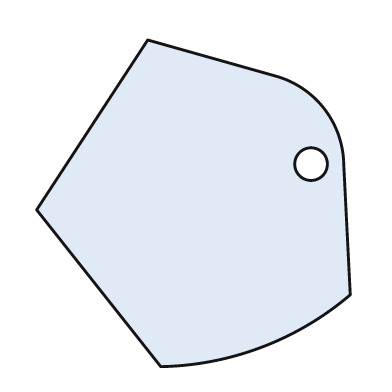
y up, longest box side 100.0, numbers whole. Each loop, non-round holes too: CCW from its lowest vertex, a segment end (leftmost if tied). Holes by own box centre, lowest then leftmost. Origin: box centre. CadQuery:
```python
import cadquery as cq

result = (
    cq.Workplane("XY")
    .moveTo(-10.0, -50.0)
    .threePointArc((21.0, -44.0), (48.0, -28.0))
    .lineTo(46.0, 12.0)
    .threePointArc((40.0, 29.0), (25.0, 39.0))
    .lineTo(-14.0, 50.0)
    .lineTo(-48.0, -2.0)
    .close()
    .moveTo(36.0, 12.0)
    .circle(5.0)
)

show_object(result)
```